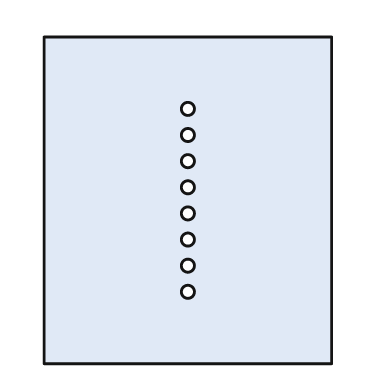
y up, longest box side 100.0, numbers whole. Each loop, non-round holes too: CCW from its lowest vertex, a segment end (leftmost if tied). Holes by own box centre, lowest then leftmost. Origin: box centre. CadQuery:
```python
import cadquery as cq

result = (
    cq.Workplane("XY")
    .moveTo(-44.0, -50.0)
    .lineTo(44.0, -50.0)
    .lineTo(44.0, 50.0)
    .lineTo(-44.0, 50.0)
    .close()
    .moveTo(0.0, -28.0)
    .circle(2.0)
    .moveTo(0.0, -20.0)
    .circle(2.0)
    .moveTo(0.0, -12.0)
    .circle(2.0)
    .moveTo(0.0, -4.0)
    .circle(2.0)
    .moveTo(0.0, 4.0)
    .circle(2.0)
    .moveTo(0.0, 12.0)
    .circle(2.0)
    .moveTo(0.0, 20.0)
    .circle(2.0)
    .moveTo(0.0, 28.0)
    .circle(2.0)
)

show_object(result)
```